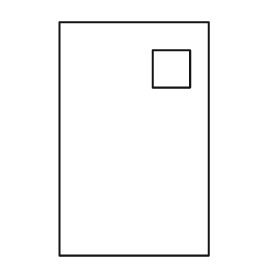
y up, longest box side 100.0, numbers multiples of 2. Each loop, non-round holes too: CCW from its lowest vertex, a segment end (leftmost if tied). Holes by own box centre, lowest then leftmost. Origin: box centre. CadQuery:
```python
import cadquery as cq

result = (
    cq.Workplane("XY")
    .moveTo(-32.0, -50.0)
    .lineTo(32.0, -50.0)
    .lineTo(32.0, 50.0)
    .lineTo(-32.0, 50.0)
    .close()
    .moveTo(8.0, 22.0)
    .lineTo(24.0, 22.0)
    .lineTo(24.0, 38.0)
    .lineTo(8.0, 38.0)
    .close()
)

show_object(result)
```